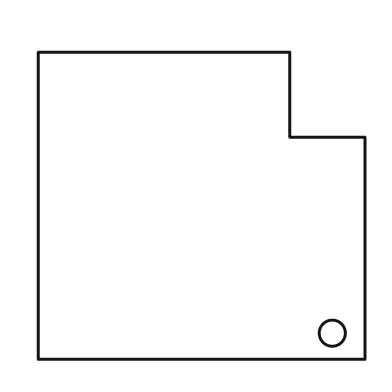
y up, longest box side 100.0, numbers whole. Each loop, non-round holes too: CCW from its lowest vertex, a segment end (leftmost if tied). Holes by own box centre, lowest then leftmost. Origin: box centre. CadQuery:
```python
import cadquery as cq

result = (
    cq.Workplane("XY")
    .moveTo(-50.0, -47.0)
    .lineTo(50.0, -47.0)
    .lineTo(50.0, 21.0)
    .lineTo(27.0, 21.0)
    .lineTo(27.0, 47.0)
    .lineTo(-50.0, 47.0)
    .close()
    .moveTo(40.0, -39.0)
    .circle(4.0)
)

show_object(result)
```